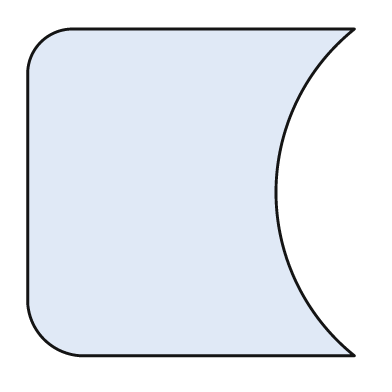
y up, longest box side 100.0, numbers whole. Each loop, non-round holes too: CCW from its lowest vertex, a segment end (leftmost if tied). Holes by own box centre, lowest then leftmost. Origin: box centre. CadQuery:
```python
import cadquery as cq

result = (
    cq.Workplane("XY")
    .moveTo(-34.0, -50.0)
    .lineTo(50.0, -50.0)
    .threePointArc((26.0, 0.0), (50.0, 50.0))
    .lineTo(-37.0, 50.0)
    .threePointArc((-46.0, 46.0), (-50.0, 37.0))
    .lineTo(-50.0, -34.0)
    .threePointArc((-45.0, -45.0), (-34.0, -50.0))
    .close()
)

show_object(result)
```